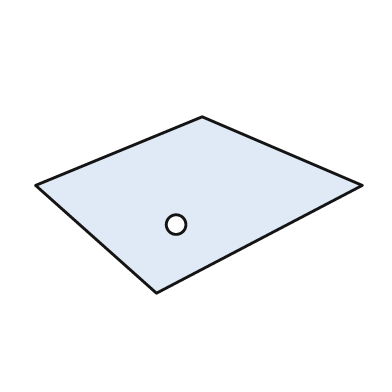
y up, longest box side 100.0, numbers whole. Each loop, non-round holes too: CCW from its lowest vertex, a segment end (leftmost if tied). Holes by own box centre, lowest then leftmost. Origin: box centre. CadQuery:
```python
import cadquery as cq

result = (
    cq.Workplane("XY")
    .moveTo(-13.0, -27.0)
    .lineTo(50.0, 6.0)
    .lineTo(1.0, 27.0)
    .lineTo(-50.0, 6.0)
    .close()
    .moveTo(-7.0, -6.0)
    .circle(3.0)
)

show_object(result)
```